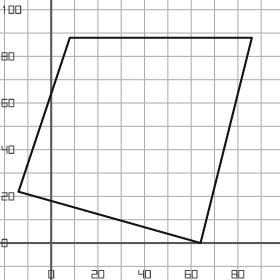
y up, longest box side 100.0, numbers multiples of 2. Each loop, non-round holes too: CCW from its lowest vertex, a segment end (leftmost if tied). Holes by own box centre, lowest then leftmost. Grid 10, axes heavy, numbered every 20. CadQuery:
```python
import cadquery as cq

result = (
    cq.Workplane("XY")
    .moveTo(64.0, 0.0)
    .lineTo(86.0, 88.0)
    .lineTo(8.0, 88.0)
    .lineTo(-14.0, 22.0)
    .close()
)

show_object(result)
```